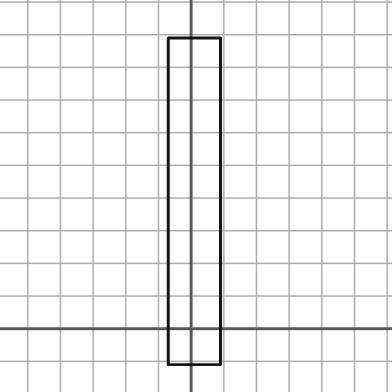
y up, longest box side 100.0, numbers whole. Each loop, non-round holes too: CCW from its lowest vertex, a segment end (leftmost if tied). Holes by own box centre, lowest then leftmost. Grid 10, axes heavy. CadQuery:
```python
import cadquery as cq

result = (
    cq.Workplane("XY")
    .moveTo(-7.0, -11.0)
    .lineTo(9.0, -11.0)
    .lineTo(9.0, 89.0)
    .lineTo(-7.0, 89.0)
    .close()
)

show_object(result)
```